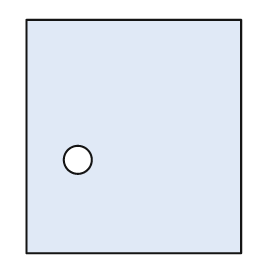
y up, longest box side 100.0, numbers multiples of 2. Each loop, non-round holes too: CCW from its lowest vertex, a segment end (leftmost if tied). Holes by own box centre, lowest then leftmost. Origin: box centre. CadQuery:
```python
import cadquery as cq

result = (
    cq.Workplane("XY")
    .moveTo(-46.0, -50.0)
    .lineTo(46.0, -50.0)
    .lineTo(46.0, 50.0)
    .lineTo(-46.0, 50.0)
    .close()
    .moveTo(-24.0, -10.0)
    .circle(6.0)
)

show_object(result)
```